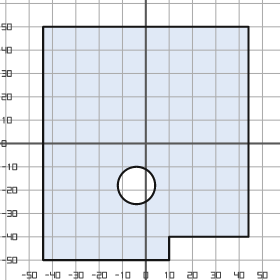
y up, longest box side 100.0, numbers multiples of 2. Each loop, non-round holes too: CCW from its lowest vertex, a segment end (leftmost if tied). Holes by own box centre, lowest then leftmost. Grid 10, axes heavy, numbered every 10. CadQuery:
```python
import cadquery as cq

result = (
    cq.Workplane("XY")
    .moveTo(-44.0, -50.0)
    .lineTo(10.0, -50.0)
    .lineTo(10.0, -40.0)
    .lineTo(44.0, -40.0)
    .lineTo(44.0, 50.0)
    .lineTo(-44.0, 50.0)
    .close()
    .moveTo(-4.0, -18.0)
    .circle(8.0)
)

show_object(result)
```